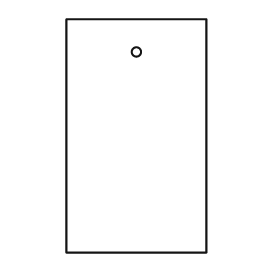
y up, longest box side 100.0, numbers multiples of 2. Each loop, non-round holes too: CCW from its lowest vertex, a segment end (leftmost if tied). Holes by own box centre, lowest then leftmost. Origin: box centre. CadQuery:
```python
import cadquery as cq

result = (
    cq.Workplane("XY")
    .moveTo(-30.0, -50.0)
    .lineTo(30.0, -50.0)
    .lineTo(30.0, 50.0)
    .lineTo(-30.0, 50.0)
    .close()
    .moveTo(0.0, 36.0)
    .circle(2.0)
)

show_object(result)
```